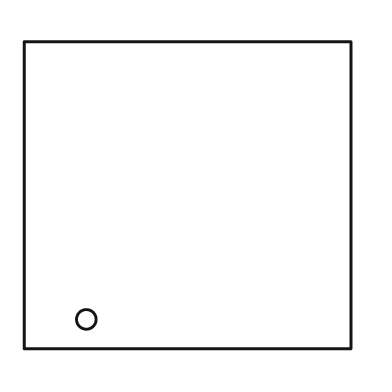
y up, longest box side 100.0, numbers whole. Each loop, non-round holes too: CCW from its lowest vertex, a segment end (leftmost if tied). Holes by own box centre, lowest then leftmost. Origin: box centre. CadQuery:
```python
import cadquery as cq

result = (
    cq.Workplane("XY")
    .moveTo(-50.0, -47.0)
    .lineTo(50.0, -47.0)
    .lineTo(50.0, 47.0)
    .lineTo(-50.0, 47.0)
    .close()
    .moveTo(-31.0, -38.0)
    .circle(3.0)
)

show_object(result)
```